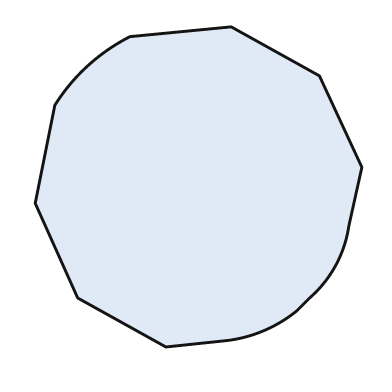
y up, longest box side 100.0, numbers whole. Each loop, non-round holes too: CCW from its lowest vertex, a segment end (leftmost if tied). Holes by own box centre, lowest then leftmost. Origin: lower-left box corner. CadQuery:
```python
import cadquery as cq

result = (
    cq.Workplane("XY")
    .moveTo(40.0, 0.0)
    .lineTo(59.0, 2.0)
    .threePointArc((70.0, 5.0), (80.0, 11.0))
    .lineTo(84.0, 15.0)
    .threePointArc((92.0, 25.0), (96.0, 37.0))
    .lineTo(100.0, 55.0)
    .lineTo(87.0, 83.0)
    .lineTo(60.0, 98.0)
    .lineTo(29.0, 95.0)
    .threePointArc((16.0, 86.0), (6.0, 74.0))
    .lineTo(0.0, 44.0)
    .lineTo(13.0, 15.0)
    .close()
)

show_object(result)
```